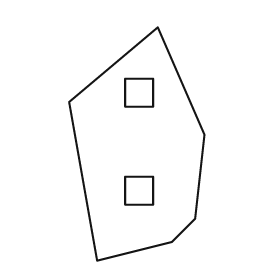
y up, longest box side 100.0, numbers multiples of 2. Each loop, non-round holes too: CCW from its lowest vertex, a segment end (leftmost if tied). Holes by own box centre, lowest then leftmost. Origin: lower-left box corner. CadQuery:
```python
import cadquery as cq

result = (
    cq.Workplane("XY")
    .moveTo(12.0, 0.0)
    .lineTo(44.0, 8.0)
    .lineTo(54.0, 18.0)
    .lineTo(58.0, 54.0)
    .lineTo(38.0, 100.0)
    .lineTo(0.0, 68.0)
    .close()
    .moveTo(24.0, 24.0)
    .lineTo(36.0, 24.0)
    .lineTo(36.0, 36.0)
    .lineTo(24.0, 36.0)
    .close()
    .moveTo(24.0, 66.0)
    .lineTo(36.0, 66.0)
    .lineTo(36.0, 78.0)
    .lineTo(24.0, 78.0)
    .close()
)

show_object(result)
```